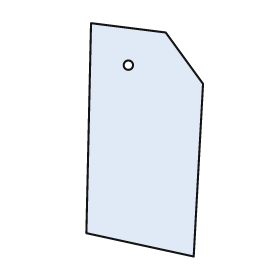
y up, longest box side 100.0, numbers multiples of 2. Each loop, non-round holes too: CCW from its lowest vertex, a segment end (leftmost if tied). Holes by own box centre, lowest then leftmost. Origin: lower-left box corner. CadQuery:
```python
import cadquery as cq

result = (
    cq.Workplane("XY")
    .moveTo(46.0, 0.0)
    .lineTo(50.0, 74.0)
    .lineTo(34.0, 96.0)
    .lineTo(2.0, 100.0)
    .lineTo(0.0, 10.0)
    .close()
    .moveTo(18.0, 82.0)
    .circle(2.0)
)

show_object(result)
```